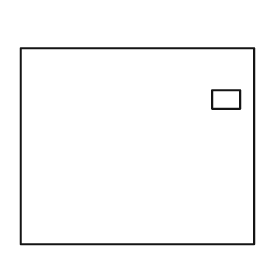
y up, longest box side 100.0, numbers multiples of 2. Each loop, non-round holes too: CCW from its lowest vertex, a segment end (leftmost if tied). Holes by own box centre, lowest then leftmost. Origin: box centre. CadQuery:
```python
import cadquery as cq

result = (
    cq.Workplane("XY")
    .moveTo(-50.0, -42.0)
    .lineTo(50.0, -42.0)
    .lineTo(50.0, 42.0)
    .lineTo(-50.0, 42.0)
    .close()
    .moveTo(32.0, 16.0)
    .lineTo(44.0, 16.0)
    .lineTo(44.0, 24.0)
    .lineTo(32.0, 24.0)
    .close()
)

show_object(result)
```